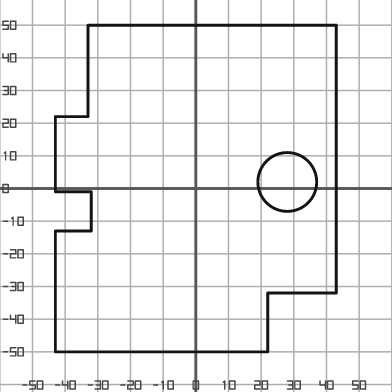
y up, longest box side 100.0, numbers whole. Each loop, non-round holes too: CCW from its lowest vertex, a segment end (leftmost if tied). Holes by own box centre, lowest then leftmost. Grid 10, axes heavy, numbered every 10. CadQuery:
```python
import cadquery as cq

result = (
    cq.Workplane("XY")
    .moveTo(-43.0, -50.0)
    .lineTo(22.0, -50.0)
    .lineTo(22.0, -32.0)
    .lineTo(43.0, -32.0)
    .lineTo(43.0, 50.0)
    .lineTo(-33.0, 50.0)
    .lineTo(-33.0, 22.0)
    .lineTo(-43.0, 22.0)
    .lineTo(-43.0, -1.0)
    .lineTo(-32.0, -1.0)
    .lineTo(-32.0, -13.0)
    .lineTo(-43.0, -13.0)
    .close()
    .moveTo(28.0, 2.0)
    .circle(9.0)
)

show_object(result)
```